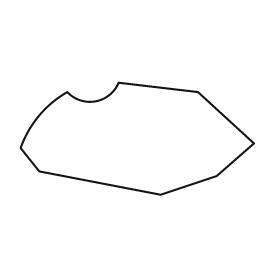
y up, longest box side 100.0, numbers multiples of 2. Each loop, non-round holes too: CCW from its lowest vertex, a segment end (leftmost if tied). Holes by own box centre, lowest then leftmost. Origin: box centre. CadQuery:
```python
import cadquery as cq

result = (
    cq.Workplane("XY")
    .moveTo(10.0, -24.0)
    .lineTo(34.0, -16.0)
    .lineTo(50.0, -2.0)
    .lineTo(26.0, 20.0)
    .lineTo(-8.0, 24.0)
    .threePointArc((-18.0, 16.0), (-30.0, 20.0))
    .threePointArc((-42.0, 10.0), (-50.0, -4.0))
    .lineTo(-42.0, -14.0)
    .close()
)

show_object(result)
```